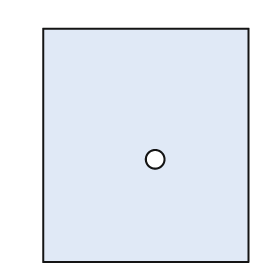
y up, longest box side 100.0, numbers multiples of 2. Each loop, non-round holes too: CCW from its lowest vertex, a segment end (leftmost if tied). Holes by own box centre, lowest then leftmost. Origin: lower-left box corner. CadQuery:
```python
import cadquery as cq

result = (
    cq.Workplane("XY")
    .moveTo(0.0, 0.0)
    .lineTo(88.0, 0.0)
    .lineTo(88.0, 100.0)
    .lineTo(0.0, 100.0)
    .close()
    .moveTo(48.0, 44.0)
    .circle(4.0)
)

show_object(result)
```